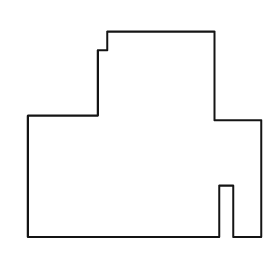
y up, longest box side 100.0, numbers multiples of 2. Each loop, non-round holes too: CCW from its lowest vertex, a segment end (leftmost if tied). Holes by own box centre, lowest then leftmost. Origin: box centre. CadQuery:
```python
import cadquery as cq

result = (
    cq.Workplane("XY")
    .moveTo(-50.0, -44.0)
    .lineTo(32.0, -44.0)
    .lineTo(32.0, -22.0)
    .lineTo(38.0, -22.0)
    .lineTo(38.0, -44.0)
    .lineTo(50.0, -44.0)
    .lineTo(50.0, 6.0)
    .lineTo(30.0, 6.0)
    .lineTo(30.0, 44.0)
    .lineTo(-16.0, 44.0)
    .lineTo(-16.0, 36.0)
    .lineTo(-20.0, 36.0)
    .lineTo(-20.0, 8.0)
    .lineTo(-50.0, 8.0)
    .close()
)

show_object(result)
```